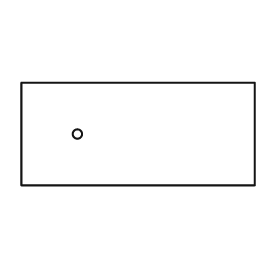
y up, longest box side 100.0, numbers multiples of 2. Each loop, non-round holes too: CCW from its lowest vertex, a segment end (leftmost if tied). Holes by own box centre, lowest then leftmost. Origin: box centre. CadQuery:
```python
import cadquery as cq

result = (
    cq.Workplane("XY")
    .moveTo(-50.0, -22.0)
    .lineTo(50.0, -22.0)
    .lineTo(50.0, 22.0)
    .lineTo(-50.0, 22.0)
    .close()
    .moveTo(-26.0, 0.0)
    .circle(2.0)
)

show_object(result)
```